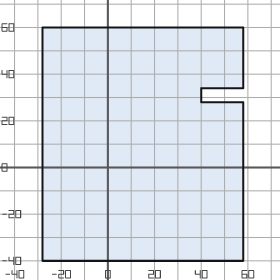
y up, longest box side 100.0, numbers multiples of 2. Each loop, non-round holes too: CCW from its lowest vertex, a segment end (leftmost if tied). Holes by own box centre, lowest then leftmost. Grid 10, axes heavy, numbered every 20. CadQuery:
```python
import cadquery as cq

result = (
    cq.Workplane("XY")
    .moveTo(-28.0, -40.0)
    .lineTo(58.0, -40.0)
    .lineTo(58.0, 28.0)
    .lineTo(40.0, 28.0)
    .lineTo(40.0, 34.0)
    .lineTo(58.0, 34.0)
    .lineTo(58.0, 60.0)
    .lineTo(-28.0, 60.0)
    .close()
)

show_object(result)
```